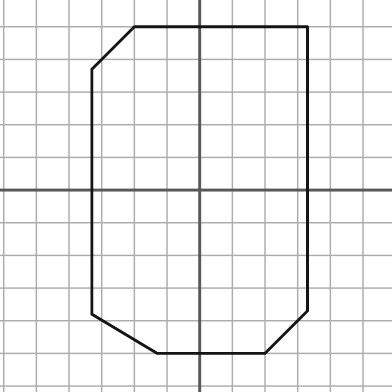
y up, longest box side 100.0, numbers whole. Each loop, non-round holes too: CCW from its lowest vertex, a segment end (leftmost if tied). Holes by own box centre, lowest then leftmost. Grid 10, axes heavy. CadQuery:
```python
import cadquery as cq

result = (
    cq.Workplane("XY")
    .moveTo(-13.0, -50.0)
    .lineTo(20.0, -50.0)
    .lineTo(33.0, -37.0)
    .lineTo(33.0, 50.0)
    .lineTo(-20.0, 50.0)
    .lineTo(-33.0, 37.0)
    .lineTo(-33.0, -38.0)
    .close()
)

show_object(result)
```